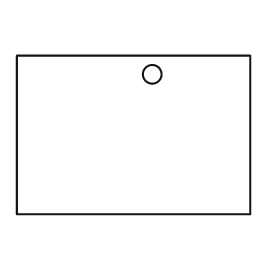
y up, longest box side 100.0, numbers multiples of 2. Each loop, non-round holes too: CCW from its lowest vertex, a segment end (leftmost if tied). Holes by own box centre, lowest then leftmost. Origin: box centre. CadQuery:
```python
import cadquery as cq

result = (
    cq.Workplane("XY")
    .moveTo(-50.0, -34.0)
    .lineTo(50.0, -34.0)
    .lineTo(50.0, 34.0)
    .lineTo(-50.0, 34.0)
    .close()
    .moveTo(8.0, 26.0)
    .circle(4.0)
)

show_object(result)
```